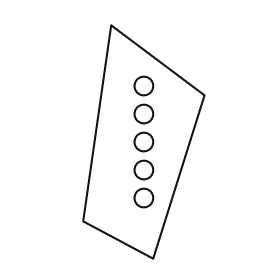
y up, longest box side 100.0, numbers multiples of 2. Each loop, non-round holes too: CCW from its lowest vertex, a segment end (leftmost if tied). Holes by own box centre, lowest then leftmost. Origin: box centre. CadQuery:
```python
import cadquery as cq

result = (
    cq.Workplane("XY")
    .moveTo(4.0, -50.0)
    .lineTo(26.0, 20.0)
    .lineTo(-14.0, 50.0)
    .lineTo(-26.0, -34.0)
    .close()
    .moveTo(0.0, -24.0)
    .circle(4.0)
    .moveTo(0.0, -12.0)
    .circle(4.0)
    .moveTo(0.0, 0.0)
    .circle(4.0)
    .moveTo(0.0, 12.0)
    .circle(4.0)
    .moveTo(0.0, 24.0)
    .circle(4.0)
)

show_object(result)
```